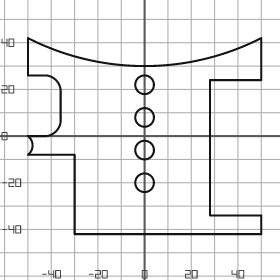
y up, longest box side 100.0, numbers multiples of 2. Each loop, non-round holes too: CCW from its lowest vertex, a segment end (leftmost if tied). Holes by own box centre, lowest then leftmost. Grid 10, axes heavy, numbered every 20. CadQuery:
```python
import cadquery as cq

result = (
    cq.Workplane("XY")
    .moveTo(-30.0, -42.0)
    .lineTo(50.0, -42.0)
    .lineTo(50.0, -34.0)
    .lineTo(28.0, -34.0)
    .lineTo(28.0, 24.0)
    .lineTo(50.0, 24.0)
    .lineTo(50.0, 42.0)
    .threePointArc((0.0, 30.0), (-50.0, 42.0))
    .lineTo(-50.0, 26.0)
    .lineTo(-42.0, 26.0)
    .threePointArc((-38.0, 24.0), (-36.0, 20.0))
    .lineTo(-36.0, 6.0)
    .threePointArc((-38.0, 2.0), (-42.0, 0.0))
    .lineTo(-50.0, 0.0)
    .threePointArc((-48.0, -4.0), (-50.0, -8.0))
    .lineTo(-30.0, -8.0)
    .close()
    .moveTo(0.0, -20.0)
    .circle(4.0)
    .moveTo(0.0, -6.0)
    .circle(4.0)
    .moveTo(0.0, 8.0)
    .circle(4.0)
    .moveTo(0.0, 22.0)
    .circle(4.0)
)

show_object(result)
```